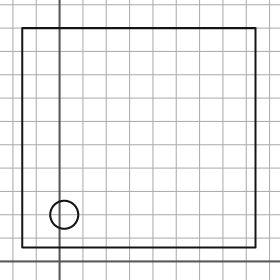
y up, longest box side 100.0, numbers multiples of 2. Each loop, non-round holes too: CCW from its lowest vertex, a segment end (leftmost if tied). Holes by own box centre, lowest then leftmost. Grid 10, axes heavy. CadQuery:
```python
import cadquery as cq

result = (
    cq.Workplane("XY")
    .moveTo(-16.0, 6.0)
    .lineTo(84.0, 6.0)
    .lineTo(84.0, 100.0)
    .lineTo(-16.0, 100.0)
    .close()
    .moveTo(2.0, 20.0)
    .circle(6.0)
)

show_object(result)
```